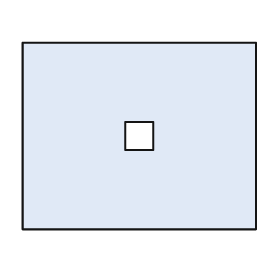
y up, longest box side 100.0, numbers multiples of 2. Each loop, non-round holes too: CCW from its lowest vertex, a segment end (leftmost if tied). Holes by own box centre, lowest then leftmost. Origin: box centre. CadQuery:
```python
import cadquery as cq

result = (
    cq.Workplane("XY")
    .moveTo(-50.0, -40.0)
    .lineTo(50.0, -40.0)
    .lineTo(50.0, 40.0)
    .lineTo(-50.0, 40.0)
    .close()
    .moveTo(-6.0, -6.0)
    .lineTo(6.0, -6.0)
    .lineTo(6.0, 6.0)
    .lineTo(-6.0, 6.0)
    .close()
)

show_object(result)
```